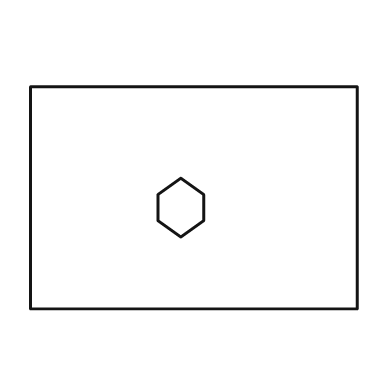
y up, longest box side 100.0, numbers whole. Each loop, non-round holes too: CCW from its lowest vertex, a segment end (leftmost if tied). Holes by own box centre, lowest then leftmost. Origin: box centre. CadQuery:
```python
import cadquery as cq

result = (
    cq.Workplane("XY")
    .moveTo(-50.0, -34.0)
    .lineTo(50.0, -34.0)
    .lineTo(50.0, 34.0)
    .lineTo(-50.0, 34.0)
    .close()
    .moveTo(-4.0, -12.0)
    .lineTo(3.0, -7.0)
    .lineTo(3.0, 1.0)
    .lineTo(-4.0, 6.0)
    .lineTo(-11.0, 1.0)
    .lineTo(-11.0, -7.0)
    .close()
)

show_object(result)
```